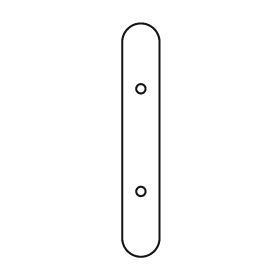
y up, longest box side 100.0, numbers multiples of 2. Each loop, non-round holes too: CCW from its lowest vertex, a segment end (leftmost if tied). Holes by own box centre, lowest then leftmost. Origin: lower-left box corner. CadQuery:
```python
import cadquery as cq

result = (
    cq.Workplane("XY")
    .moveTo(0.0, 8.0)
    .threePointArc((8.0, 0.0), (16.0, 8.0))
    .lineTo(16.0, 92.0)
    .threePointArc((8.0, 100.0), (0.0, 92.0))
    .close()
    .moveTo(8.0, 28.0)
    .circle(2.0)
    .moveTo(8.0, 72.0)
    .circle(2.0)
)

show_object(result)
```